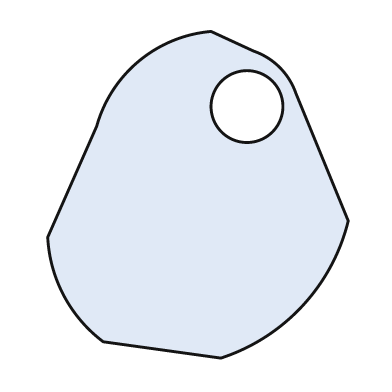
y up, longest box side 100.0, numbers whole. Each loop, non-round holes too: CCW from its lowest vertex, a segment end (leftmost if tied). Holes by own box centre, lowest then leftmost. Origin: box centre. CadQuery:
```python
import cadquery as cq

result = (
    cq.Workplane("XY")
    .moveTo(7.0, -50.0)
    .threePointArc((32.0, -34.0), (46.0, -8.0))
    .lineTo(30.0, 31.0)
    .threePointArc((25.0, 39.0), (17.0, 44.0))
    .lineTo(4.0, 50.0)
    .threePointArc((-18.0, 41.0), (-31.0, 21.0))
    .lineTo(-46.0, -13.0)
    .threePointArc((-41.0, -31.0), (-29.0, -45.0))
    .close()
    .moveTo(15.0, 27.0)
    .circle(11.0)
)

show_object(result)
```